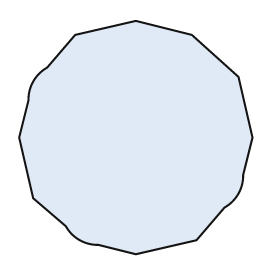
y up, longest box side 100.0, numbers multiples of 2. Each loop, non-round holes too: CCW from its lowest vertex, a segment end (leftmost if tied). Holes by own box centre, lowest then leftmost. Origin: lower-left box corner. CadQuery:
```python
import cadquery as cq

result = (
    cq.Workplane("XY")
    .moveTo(50.0, 0.0)
    .lineTo(76.0, 6.0)
    .lineTo(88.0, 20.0)
    .threePointArc((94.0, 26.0), (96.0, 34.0))
    .lineTo(100.0, 50.0)
    .lineTo(94.0, 76.0)
    .lineTo(74.0, 94.0)
    .lineTo(50.0, 100.0)
    .lineTo(24.0, 94.0)
    .lineTo(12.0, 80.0)
    .threePointArc((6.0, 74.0), (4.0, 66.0))
    .lineTo(0.0, 50.0)
    .lineTo(6.0, 24.0)
    .lineTo(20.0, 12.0)
    .threePointArc((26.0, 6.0), (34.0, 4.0))
    .close()
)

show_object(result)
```